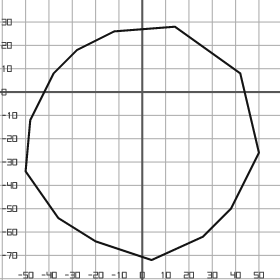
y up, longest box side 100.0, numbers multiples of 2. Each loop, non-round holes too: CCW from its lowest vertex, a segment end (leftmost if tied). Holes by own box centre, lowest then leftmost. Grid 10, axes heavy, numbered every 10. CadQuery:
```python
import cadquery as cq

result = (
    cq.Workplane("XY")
    .moveTo(4.0, -72.0)
    .lineTo(26.0, -62.0)
    .lineTo(38.0, -50.0)
    .lineTo(50.0, -26.0)
    .lineTo(42.0, 8.0)
    .lineTo(14.0, 28.0)
    .lineTo(-12.0, 26.0)
    .lineTo(-28.0, 18.0)
    .lineTo(-38.0, 8.0)
    .lineTo(-48.0, -12.0)
    .lineTo(-50.0, -34.0)
    .lineTo(-36.0, -54.0)
    .lineTo(-20.0, -64.0)
    .close()
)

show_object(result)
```